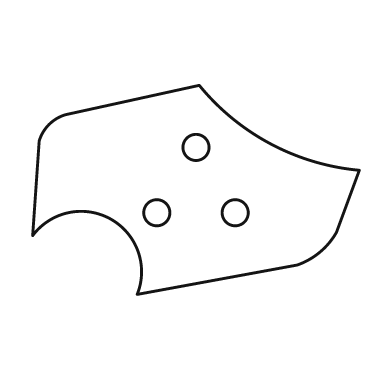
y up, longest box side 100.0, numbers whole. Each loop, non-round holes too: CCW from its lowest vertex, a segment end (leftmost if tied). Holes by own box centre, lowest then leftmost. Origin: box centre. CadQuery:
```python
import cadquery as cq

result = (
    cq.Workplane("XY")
    .moveTo(-18.0, -32.0)
    .lineTo(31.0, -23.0)
    .threePointArc((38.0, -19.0), (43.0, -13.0))
    .lineTo(50.0, 6.0)
    .threePointArc((23.0, 14.0), (1.0, 32.0))
    .lineTo(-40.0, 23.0)
    .threePointArc((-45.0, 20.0), (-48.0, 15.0))
    .lineTo(-50.0, -14.0)
    .threePointArc((-26.0, -9.0), (-18.0, -32.0))
    .close()
    .moveTo(-12.0, -7.0)
    .circle(4.0)
    .moveTo(12.0, -7.0)
    .circle(4.0)
    .moveTo(0.0, 13.0)
    .circle(4.0)
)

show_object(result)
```